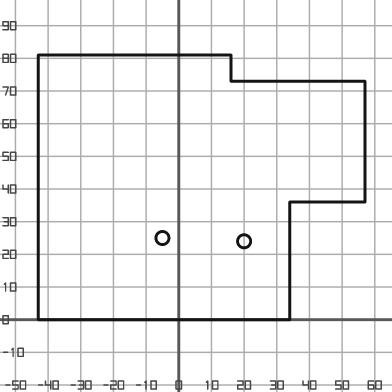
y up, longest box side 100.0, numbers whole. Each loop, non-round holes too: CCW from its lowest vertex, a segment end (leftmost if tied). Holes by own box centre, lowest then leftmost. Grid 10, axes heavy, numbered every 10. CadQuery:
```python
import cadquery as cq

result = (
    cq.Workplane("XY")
    .moveTo(-43.0, 0.0)
    .lineTo(34.0, 0.0)
    .lineTo(34.0, 36.0)
    .lineTo(57.0, 36.0)
    .lineTo(57.0, 73.0)
    .lineTo(16.0, 73.0)
    .lineTo(16.0, 81.0)
    .lineTo(-43.0, 81.0)
    .close()
    .moveTo(20.0, 24.0)
    .circle(2.0)
    .moveTo(-5.0, 25.0)
    .circle(2.0)
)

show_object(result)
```